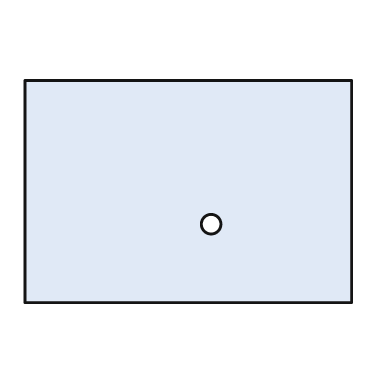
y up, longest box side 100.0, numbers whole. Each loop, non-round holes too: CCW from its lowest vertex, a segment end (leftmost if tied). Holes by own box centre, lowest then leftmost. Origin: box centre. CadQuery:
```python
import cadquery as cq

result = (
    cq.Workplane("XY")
    .moveTo(-50.0, -34.0)
    .lineTo(50.0, -34.0)
    .lineTo(50.0, 34.0)
    .lineTo(-50.0, 34.0)
    .close()
    .moveTo(7.0, -10.0)
    .circle(3.0)
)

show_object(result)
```